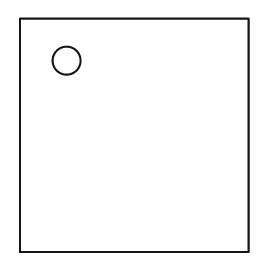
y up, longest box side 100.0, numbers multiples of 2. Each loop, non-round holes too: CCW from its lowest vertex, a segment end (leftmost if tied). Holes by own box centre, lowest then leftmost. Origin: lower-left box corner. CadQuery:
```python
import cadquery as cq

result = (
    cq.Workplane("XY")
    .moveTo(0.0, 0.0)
    .lineTo(98.0, 0.0)
    .lineTo(98.0, 100.0)
    .lineTo(0.0, 100.0)
    .close()
    .moveTo(20.0, 82.0)
    .circle(6.0)
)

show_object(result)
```